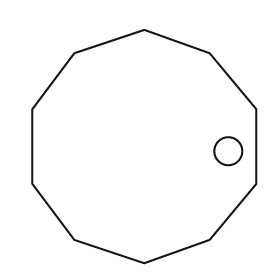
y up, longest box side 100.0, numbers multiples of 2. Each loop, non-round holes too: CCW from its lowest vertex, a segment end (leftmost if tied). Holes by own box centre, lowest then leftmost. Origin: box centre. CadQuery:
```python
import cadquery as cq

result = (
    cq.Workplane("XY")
    .moveTo(0.0, -50.0)
    .lineTo(28.0, -40.0)
    .lineTo(48.0, -16.0)
    .lineTo(48.0, 16.0)
    .lineTo(28.0, 40.0)
    .lineTo(0.0, 50.0)
    .lineTo(-30.0, 40.0)
    .lineTo(-48.0, 16.0)
    .lineTo(-48.0, -16.0)
    .lineTo(-30.0, -40.0)
    .close()
    .moveTo(36.0, -2.0)
    .circle(6.0)
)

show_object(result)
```